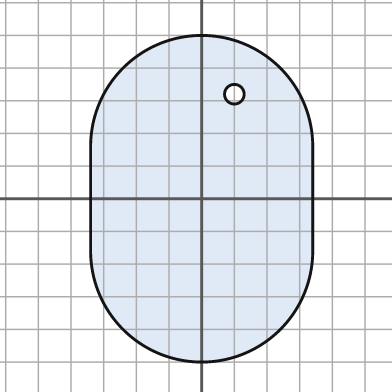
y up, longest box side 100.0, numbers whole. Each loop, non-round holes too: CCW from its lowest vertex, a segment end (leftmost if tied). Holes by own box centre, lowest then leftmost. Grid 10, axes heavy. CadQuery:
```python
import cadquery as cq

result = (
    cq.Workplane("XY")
    .moveTo(-34.0, -16.0)
    .threePointArc((0.0, -50.0), (34.0, -16.0))
    .lineTo(34.0, 16.0)
    .threePointArc((0.0, 50.0), (-34.0, 16.0))
    .close()
    .moveTo(10.0, 32.0)
    .circle(3.0)
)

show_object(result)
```